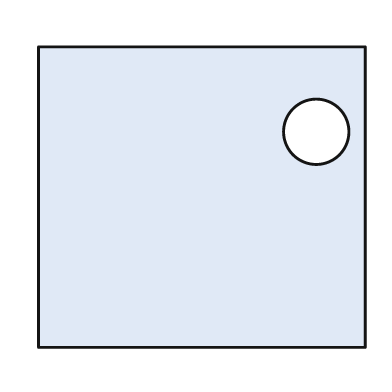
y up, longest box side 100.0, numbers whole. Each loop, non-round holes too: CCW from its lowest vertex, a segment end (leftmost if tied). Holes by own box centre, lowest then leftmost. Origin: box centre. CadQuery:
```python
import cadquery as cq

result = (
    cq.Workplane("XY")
    .moveTo(-50.0, -46.0)
    .lineTo(50.0, -46.0)
    .lineTo(50.0, 46.0)
    .lineTo(-50.0, 46.0)
    .close()
    .moveTo(35.0, 20.0)
    .circle(10.0)
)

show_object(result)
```